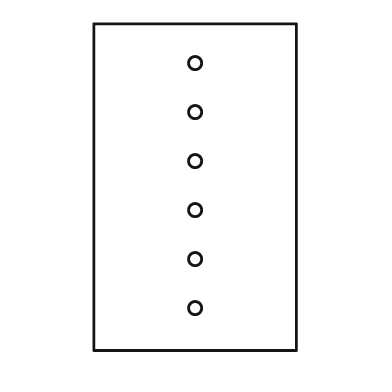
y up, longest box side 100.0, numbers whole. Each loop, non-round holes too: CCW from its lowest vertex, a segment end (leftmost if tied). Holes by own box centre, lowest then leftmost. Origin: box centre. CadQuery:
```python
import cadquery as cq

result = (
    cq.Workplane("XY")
    .moveTo(-31.0, -50.0)
    .lineTo(31.0, -50.0)
    .lineTo(31.0, 50.0)
    .lineTo(-31.0, 50.0)
    .close()
    .moveTo(0.0, -37.0)
    .circle(2.0)
    .moveTo(0.0, -22.0)
    .circle(2.0)
    .moveTo(0.0, -7.0)
    .circle(2.0)
    .moveTo(0.0, 8.0)
    .circle(2.0)
    .moveTo(0.0, 23.0)
    .circle(2.0)
    .moveTo(0.0, 38.0)
    .circle(2.0)
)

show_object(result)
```